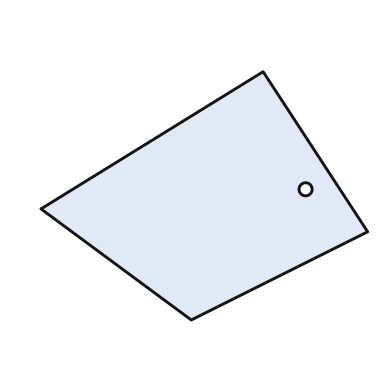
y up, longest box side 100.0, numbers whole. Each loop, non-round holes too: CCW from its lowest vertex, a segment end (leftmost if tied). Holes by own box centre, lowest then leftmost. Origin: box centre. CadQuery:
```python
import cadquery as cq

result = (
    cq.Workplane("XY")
    .moveTo(-4.0, -38.0)
    .lineTo(50.0, -11.0)
    .lineTo(18.0, 38.0)
    .lineTo(-50.0, -4.0)
    .close()
    .moveTo(31.0, 2.0)
    .circle(2.0)
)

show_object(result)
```